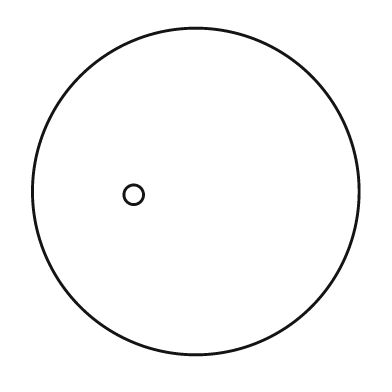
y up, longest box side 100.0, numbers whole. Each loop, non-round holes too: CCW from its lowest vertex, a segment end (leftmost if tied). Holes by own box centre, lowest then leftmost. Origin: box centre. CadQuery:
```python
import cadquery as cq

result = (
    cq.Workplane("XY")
    .moveTo(0.0, 0.0)
    .circle(50.0)
    .moveTo(-19.0, -1.0)
    .circle(3.0)
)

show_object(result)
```